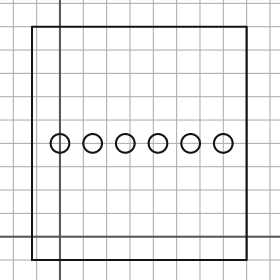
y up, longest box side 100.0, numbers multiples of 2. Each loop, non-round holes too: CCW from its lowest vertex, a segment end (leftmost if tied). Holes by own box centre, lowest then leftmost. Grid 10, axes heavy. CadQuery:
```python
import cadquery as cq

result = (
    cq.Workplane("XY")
    .moveTo(-12.0, -10.0)
    .lineTo(80.0, -10.0)
    .lineTo(80.0, 90.0)
    .lineTo(-12.0, 90.0)
    .close()
    .moveTo(0.0, 40.0)
    .circle(4.0)
    .moveTo(14.0, 40.0)
    .circle(4.0)
    .moveTo(28.0, 40.0)
    .circle(4.0)
    .moveTo(42.0, 40.0)
    .circle(4.0)
    .moveTo(56.0, 40.0)
    .circle(4.0)
    .moveTo(70.0, 40.0)
    .circle(4.0)
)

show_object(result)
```